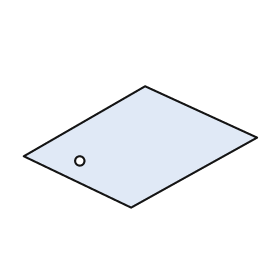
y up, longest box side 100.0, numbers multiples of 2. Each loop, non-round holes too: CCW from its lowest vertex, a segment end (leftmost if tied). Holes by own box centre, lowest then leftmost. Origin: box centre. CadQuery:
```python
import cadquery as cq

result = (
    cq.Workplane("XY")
    .moveTo(-4.0, -26.0)
    .lineTo(50.0, 4.0)
    .lineTo(2.0, 26.0)
    .lineTo(-50.0, -4.0)
    .close()
    .moveTo(-26.0, -6.0)
    .circle(2.0)
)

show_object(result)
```